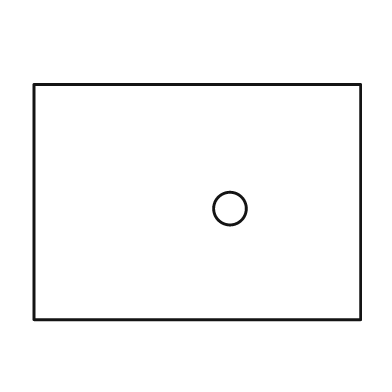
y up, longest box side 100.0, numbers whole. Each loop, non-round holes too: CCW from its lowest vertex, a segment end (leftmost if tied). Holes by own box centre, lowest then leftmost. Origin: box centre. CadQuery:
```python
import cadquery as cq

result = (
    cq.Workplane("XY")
    .moveTo(-50.0, -36.0)
    .lineTo(50.0, -36.0)
    .lineTo(50.0, 36.0)
    .lineTo(-50.0, 36.0)
    .close()
    .moveTo(10.0, -2.0)
    .circle(5.0)
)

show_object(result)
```